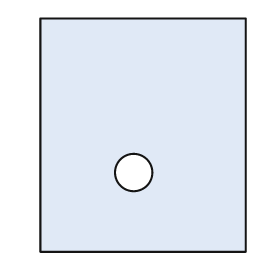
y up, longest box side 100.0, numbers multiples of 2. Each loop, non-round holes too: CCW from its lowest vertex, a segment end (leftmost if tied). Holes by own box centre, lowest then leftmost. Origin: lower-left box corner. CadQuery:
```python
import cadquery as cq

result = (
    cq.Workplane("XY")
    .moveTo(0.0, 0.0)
    .lineTo(88.0, 0.0)
    .lineTo(88.0, 100.0)
    .lineTo(0.0, 100.0)
    .close()
    .moveTo(40.0, 34.0)
    .circle(8.0)
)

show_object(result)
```